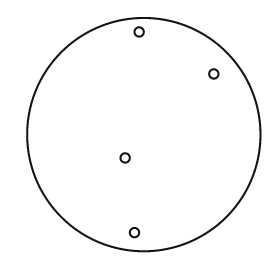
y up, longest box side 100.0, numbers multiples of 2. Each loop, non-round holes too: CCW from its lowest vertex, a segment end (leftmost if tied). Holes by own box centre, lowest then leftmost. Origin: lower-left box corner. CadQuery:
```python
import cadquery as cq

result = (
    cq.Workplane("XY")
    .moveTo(50.0, 50.0)
    .circle(50.0)
    .moveTo(46.0, 8.0)
    .circle(2.0)
    .moveTo(42.0, 40.0)
    .circle(2.0)
    .moveTo(80.0, 76.0)
    .circle(2.0)
    .moveTo(48.0, 94.0)
    .circle(2.0)
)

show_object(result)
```